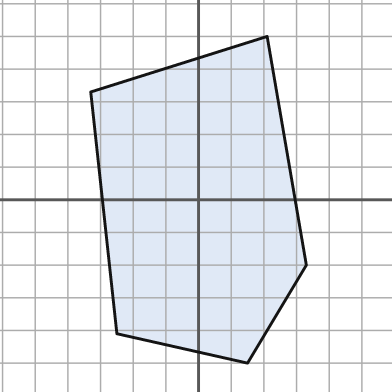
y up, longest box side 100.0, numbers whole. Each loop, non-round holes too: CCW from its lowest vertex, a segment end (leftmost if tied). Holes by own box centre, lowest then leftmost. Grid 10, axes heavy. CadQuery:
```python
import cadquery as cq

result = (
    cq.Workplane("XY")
    .moveTo(15.0, -50.0)
    .lineTo(33.0, -20.0)
    .lineTo(21.0, 50.0)
    .lineTo(-33.0, 33.0)
    .lineTo(-25.0, -41.0)
    .close()
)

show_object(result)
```